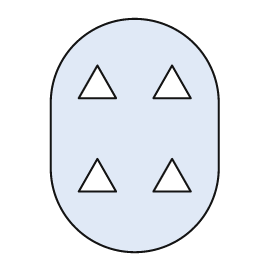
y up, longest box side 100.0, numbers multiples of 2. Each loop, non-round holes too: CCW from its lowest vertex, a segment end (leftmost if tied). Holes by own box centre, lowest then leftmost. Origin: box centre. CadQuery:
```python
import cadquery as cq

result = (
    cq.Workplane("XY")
    .moveTo(-36.0, -14.0)
    .threePointArc((0.0, -50.0), (36.0, -14.0))
    .lineTo(36.0, 14.0)
    .threePointArc((0.0, 50.0), (-36.0, 14.0))
    .close()
    .moveTo(-24.0, -24.0)
    .lineTo(-8.0, -24.0)
    .lineTo(-16.0, -10.0)
    .close()
    .moveTo(8.0, -24.0)
    .lineTo(24.0, -24.0)
    .lineTo(16.0, -10.0)
    .close()
    .moveTo(-24.0, 16.0)
    .lineTo(-8.0, 16.0)
    .lineTo(-16.0, 30.0)
    .close()
    .moveTo(8.0, 16.0)
    .lineTo(24.0, 16.0)
    .lineTo(16.0, 30.0)
    .close()
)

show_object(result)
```